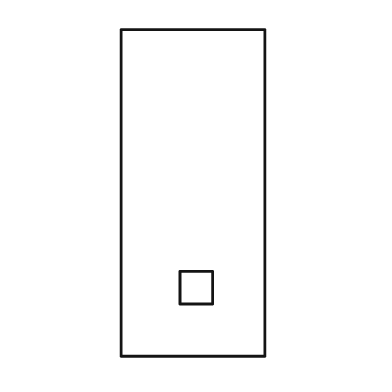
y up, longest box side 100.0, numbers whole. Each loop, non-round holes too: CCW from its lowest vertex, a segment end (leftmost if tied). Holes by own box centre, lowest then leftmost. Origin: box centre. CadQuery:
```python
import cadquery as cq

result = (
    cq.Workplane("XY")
    .moveTo(-22.0, -50.0)
    .lineTo(22.0, -50.0)
    .lineTo(22.0, 50.0)
    .lineTo(-22.0, 50.0)
    .close()
    .moveTo(-4.0, -34.0)
    .lineTo(6.0, -34.0)
    .lineTo(6.0, -24.0)
    .lineTo(-4.0, -24.0)
    .close()
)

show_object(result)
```